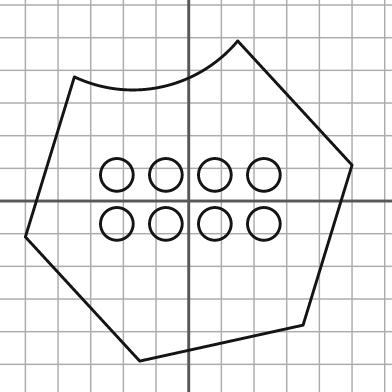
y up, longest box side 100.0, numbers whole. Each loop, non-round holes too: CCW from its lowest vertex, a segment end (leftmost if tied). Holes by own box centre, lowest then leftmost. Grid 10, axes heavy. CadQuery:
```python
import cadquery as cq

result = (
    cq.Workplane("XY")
    .moveTo(-15.0, -49.0)
    .lineTo(35.0, -38.0)
    .lineTo(50.0, 11.0)
    .lineTo(15.0, 49.0)
    .threePointArc((-8.0, 35.0), (-35.0, 38.0))
    .lineTo(-50.0, -11.0)
    .close()
    .moveTo(-22.0, -7.0)
    .circle(5.0)
    .moveTo(-7.0, -7.0)
    .circle(5.0)
    .moveTo(8.0, -7.0)
    .circle(5.0)
    .moveTo(23.0, -7.0)
    .circle(5.0)
    .moveTo(-22.0, 8.0)
    .circle(5.0)
    .moveTo(-7.0, 8.0)
    .circle(5.0)
    .moveTo(8.0, 8.0)
    .circle(5.0)
    .moveTo(23.0, 8.0)
    .circle(5.0)
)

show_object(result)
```